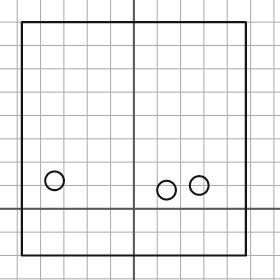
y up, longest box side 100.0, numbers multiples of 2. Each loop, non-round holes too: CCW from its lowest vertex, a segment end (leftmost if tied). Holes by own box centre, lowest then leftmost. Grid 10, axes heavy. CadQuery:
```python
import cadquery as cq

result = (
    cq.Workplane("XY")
    .moveTo(-48.0, -20.0)
    .lineTo(48.0, -20.0)
    .lineTo(48.0, 80.0)
    .lineTo(-48.0, 80.0)
    .close()
    .moveTo(14.0, 8.0)
    .circle(4.0)
    .moveTo(28.0, 10.0)
    .circle(4.0)
    .moveTo(-34.0, 12.0)
    .circle(4.0)
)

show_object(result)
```